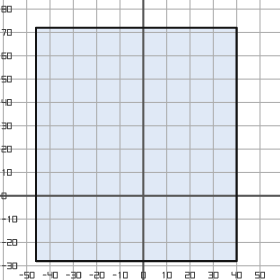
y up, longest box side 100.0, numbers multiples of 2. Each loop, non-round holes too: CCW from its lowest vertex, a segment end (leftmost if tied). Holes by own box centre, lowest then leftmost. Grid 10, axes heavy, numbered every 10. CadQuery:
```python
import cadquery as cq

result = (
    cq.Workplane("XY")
    .moveTo(-46.0, -28.0)
    .lineTo(40.0, -28.0)
    .lineTo(40.0, 72.0)
    .lineTo(-46.0, 72.0)
    .close()
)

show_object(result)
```